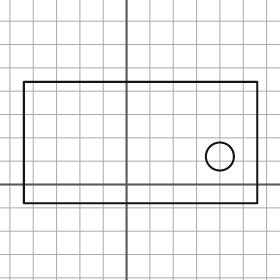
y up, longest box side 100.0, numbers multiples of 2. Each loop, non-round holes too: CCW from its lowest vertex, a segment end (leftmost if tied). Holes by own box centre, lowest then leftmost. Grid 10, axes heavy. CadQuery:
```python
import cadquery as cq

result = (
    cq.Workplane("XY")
    .moveTo(-44.0, -8.0)
    .lineTo(56.0, -8.0)
    .lineTo(56.0, 44.0)
    .lineTo(-44.0, 44.0)
    .close()
    .moveTo(40.0, 12.0)
    .circle(6.0)
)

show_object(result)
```